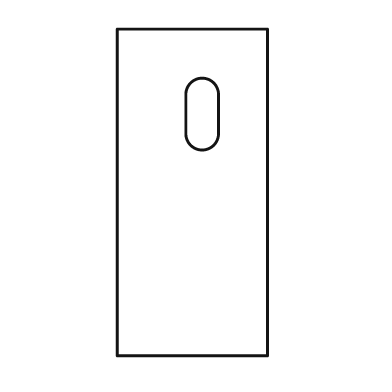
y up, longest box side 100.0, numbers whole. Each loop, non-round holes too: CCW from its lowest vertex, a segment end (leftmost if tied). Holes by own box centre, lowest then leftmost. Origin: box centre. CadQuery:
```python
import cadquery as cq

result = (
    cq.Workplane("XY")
    .moveTo(-23.0, -50.0)
    .lineTo(23.0, -50.0)
    .lineTo(23.0, 50.0)
    .lineTo(-23.0, 50.0)
    .close()
    .moveTo(-2.0, 18.0)
    .threePointArc((3.0, 13.0), (8.0, 18.0))
    .lineTo(8.0, 30.0)
    .threePointArc((3.0, 35.0), (-2.0, 30.0))
    .close()
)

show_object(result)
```